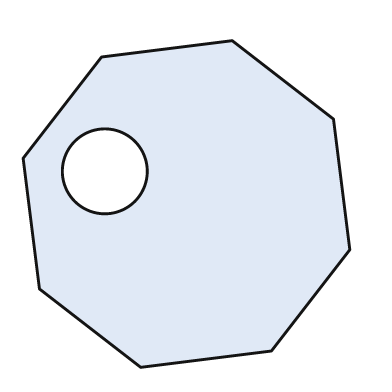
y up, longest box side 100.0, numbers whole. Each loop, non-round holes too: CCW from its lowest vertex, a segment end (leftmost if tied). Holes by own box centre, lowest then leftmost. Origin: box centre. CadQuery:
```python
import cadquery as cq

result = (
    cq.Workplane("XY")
    .moveTo(-14.0, -50.0)
    .lineTo(26.0, -45.0)
    .lineTo(50.0, -14.0)
    .lineTo(45.0, 26.0)
    .lineTo(14.0, 50.0)
    .lineTo(-26.0, 45.0)
    .lineTo(-50.0, 14.0)
    .lineTo(-45.0, -26.0)
    .close()
    .moveTo(-25.0, 10.0)
    .circle(13.0)
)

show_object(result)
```